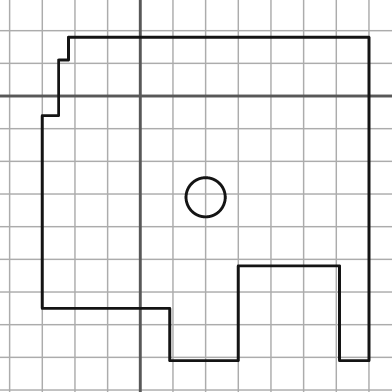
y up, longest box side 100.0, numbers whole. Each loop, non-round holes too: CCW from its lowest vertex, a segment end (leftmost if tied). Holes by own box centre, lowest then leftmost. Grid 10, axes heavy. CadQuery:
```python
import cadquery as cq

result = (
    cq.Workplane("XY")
    .moveTo(9.0, -81.0)
    .lineTo(30.0, -81.0)
    .lineTo(30.0, -52.0)
    .lineTo(61.0, -52.0)
    .lineTo(61.0, -81.0)
    .lineTo(70.0, -81.0)
    .lineTo(70.0, 18.0)
    .lineTo(-22.0, 18.0)
    .lineTo(-22.0, 11.0)
    .lineTo(-25.0, 11.0)
    .lineTo(-25.0, -6.0)
    .lineTo(-30.0, -6.0)
    .lineTo(-30.0, -65.0)
    .lineTo(9.0, -65.0)
    .close()
    .moveTo(20.0, -31.0)
    .circle(6.0)
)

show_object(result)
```